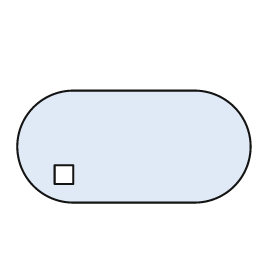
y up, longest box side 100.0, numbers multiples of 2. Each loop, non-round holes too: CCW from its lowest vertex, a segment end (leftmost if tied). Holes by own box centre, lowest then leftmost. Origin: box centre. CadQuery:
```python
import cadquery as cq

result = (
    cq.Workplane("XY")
    .moveTo(-26.0, -24.0)
    .lineTo(26.0, -24.0)
    .threePointArc((50.0, 0.0), (26.0, 24.0))
    .lineTo(-26.0, 24.0)
    .threePointArc((-50.0, 0.0), (-26.0, -24.0))
    .close()
    .moveTo(-34.0, -16.0)
    .lineTo(-26.0, -16.0)
    .lineTo(-26.0, -8.0)
    .lineTo(-34.0, -8.0)
    .close()
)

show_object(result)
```